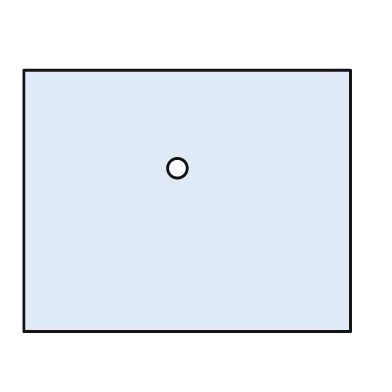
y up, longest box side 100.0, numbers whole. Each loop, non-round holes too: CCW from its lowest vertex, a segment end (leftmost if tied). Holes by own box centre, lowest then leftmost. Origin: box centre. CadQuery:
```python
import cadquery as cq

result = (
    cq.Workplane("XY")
    .moveTo(-50.0, -40.0)
    .lineTo(50.0, -40.0)
    .lineTo(50.0, 40.0)
    .lineTo(-50.0, 40.0)
    .close()
    .moveTo(-3.0, 10.0)
    .circle(3.0)
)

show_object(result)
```